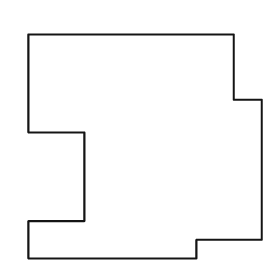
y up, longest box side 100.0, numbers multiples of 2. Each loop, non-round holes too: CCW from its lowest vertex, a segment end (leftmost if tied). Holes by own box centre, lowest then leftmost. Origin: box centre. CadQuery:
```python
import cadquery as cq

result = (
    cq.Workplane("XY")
    .moveTo(-50.0, -48.0)
    .lineTo(22.0, -48.0)
    .lineTo(22.0, -40.0)
    .lineTo(50.0, -40.0)
    .lineTo(50.0, 20.0)
    .lineTo(38.0, 20.0)
    .lineTo(38.0, 48.0)
    .lineTo(-50.0, 48.0)
    .lineTo(-50.0, 6.0)
    .lineTo(-26.0, 6.0)
    .lineTo(-26.0, -32.0)
    .lineTo(-50.0, -32.0)
    .close()
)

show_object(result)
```